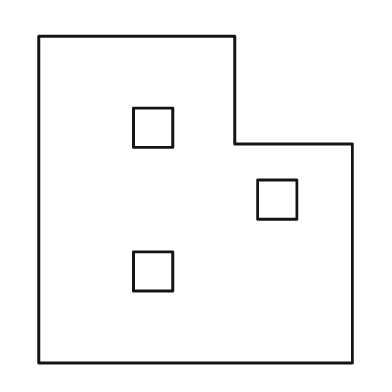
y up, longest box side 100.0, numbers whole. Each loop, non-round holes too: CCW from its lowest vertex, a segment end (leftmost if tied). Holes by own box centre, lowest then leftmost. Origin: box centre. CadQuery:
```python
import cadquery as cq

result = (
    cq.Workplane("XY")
    .moveTo(-48.0, -50.0)
    .lineTo(48.0, -50.0)
    .lineTo(48.0, 17.0)
    .lineTo(12.0, 17.0)
    .lineTo(12.0, 50.0)
    .lineTo(-48.0, 50.0)
    .close()
    .moveTo(-19.0, -28.0)
    .lineTo(-7.0, -28.0)
    .lineTo(-7.0, -16.0)
    .lineTo(-19.0, -16.0)
    .close()
    .moveTo(19.0, -6.0)
    .lineTo(31.0, -6.0)
    .lineTo(31.0, 6.0)
    .lineTo(19.0, 6.0)
    .close()
    .moveTo(-19.0, 16.0)
    .lineTo(-7.0, 16.0)
    .lineTo(-7.0, 28.0)
    .lineTo(-19.0, 28.0)
    .close()
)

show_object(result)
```